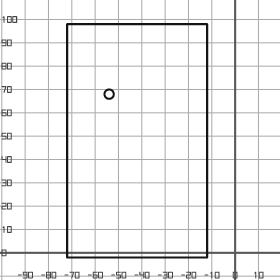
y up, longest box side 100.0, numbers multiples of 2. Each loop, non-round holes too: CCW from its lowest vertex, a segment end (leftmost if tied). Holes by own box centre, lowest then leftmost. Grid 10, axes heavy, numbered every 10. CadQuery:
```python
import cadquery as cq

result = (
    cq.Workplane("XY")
    .moveTo(-72.0, -2.0)
    .lineTo(-12.0, -2.0)
    .lineTo(-12.0, 98.0)
    .lineTo(-72.0, 98.0)
    .close()
    .moveTo(-54.0, 68.0)
    .circle(2.0)
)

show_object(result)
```